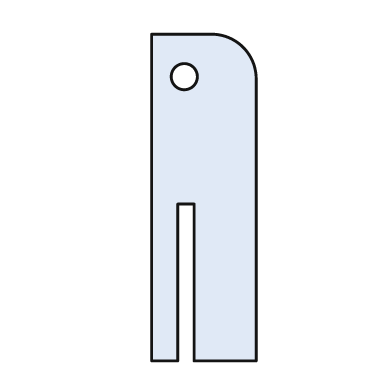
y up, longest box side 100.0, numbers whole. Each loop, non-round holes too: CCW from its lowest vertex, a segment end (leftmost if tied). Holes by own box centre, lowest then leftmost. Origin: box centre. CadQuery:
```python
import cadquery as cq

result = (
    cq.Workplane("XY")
    .moveTo(-16.0, -50.0)
    .lineTo(-8.0, -50.0)
    .lineTo(-8.0, -2.0)
    .lineTo(-3.0, -2.0)
    .lineTo(-3.0, -50.0)
    .lineTo(16.0, -50.0)
    .lineTo(16.0, 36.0)
    .threePointArc((12.0, 46.0), (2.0, 50.0))
    .lineTo(-16.0, 50.0)
    .close()
    .moveTo(-6.0, 37.0)
    .circle(4.0)
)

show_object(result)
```